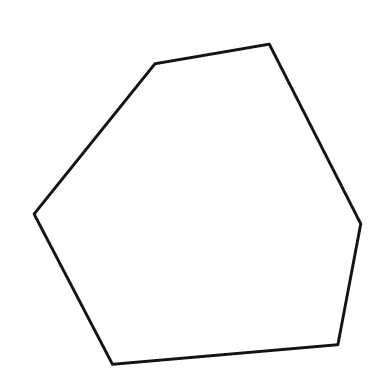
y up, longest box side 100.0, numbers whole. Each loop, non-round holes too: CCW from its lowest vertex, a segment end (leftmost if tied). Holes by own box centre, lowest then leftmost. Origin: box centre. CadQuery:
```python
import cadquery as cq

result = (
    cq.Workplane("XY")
    .moveTo(-26.0, -49.0)
    .lineTo(43.0, -43.0)
    .lineTo(50.0, -6.0)
    .lineTo(22.0, 49.0)
    .lineTo(-13.0, 43.0)
    .lineTo(-50.0, -3.0)
    .close()
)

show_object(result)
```